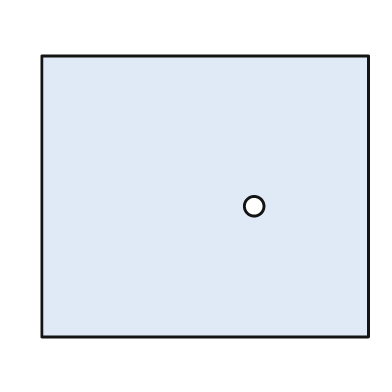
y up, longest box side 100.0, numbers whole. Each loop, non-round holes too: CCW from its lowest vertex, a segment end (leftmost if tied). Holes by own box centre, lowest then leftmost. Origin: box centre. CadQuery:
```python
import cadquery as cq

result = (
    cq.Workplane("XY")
    .moveTo(-50.0, -43.0)
    .lineTo(50.0, -43.0)
    .lineTo(50.0, 43.0)
    .lineTo(-50.0, 43.0)
    .close()
    .moveTo(15.0, -3.0)
    .circle(3.0)
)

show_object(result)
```